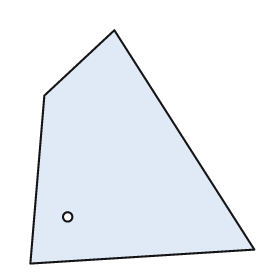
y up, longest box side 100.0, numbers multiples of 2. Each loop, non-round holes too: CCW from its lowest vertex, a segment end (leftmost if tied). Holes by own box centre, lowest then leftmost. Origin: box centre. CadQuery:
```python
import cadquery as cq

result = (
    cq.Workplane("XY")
    .moveTo(-48.0, -50.0)
    .lineTo(48.0, -44.0)
    .lineTo(-12.0, 50.0)
    .lineTo(-42.0, 22.0)
    .close()
    .moveTo(-32.0, -30.0)
    .circle(2.0)
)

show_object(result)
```